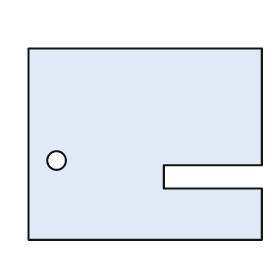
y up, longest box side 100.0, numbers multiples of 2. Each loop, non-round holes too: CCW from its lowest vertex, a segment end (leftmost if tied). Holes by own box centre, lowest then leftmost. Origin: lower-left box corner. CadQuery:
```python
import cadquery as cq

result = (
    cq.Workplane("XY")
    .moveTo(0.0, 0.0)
    .lineTo(100.0, 0.0)
    .lineTo(100.0, 22.0)
    .lineTo(58.0, 22.0)
    .lineTo(58.0, 32.0)
    .lineTo(100.0, 32.0)
    .lineTo(100.0, 82.0)
    .lineTo(0.0, 82.0)
    .close()
    .moveTo(12.0, 34.0)
    .circle(4.0)
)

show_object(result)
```